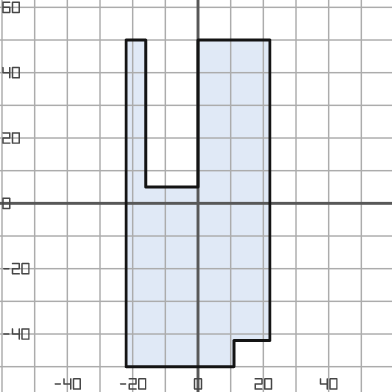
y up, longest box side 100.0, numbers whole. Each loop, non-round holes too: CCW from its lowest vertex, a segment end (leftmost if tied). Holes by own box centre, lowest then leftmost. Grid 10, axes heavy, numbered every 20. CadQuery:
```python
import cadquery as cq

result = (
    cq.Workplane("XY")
    .moveTo(-22.0, -50.0)
    .lineTo(11.0, -50.0)
    .lineTo(11.0, -42.0)
    .lineTo(22.0, -42.0)
    .lineTo(22.0, 50.0)
    .lineTo(0.0, 50.0)
    .lineTo(0.0, 5.0)
    .lineTo(-16.0, 5.0)
    .lineTo(-16.0, 50.0)
    .lineTo(-22.0, 50.0)
    .close()
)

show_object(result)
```